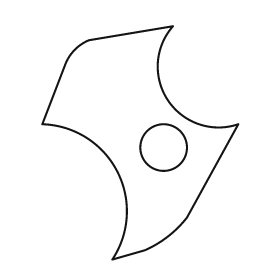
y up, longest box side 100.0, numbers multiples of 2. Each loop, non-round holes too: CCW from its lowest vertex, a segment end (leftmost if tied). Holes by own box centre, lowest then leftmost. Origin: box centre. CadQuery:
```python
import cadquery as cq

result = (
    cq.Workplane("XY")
    .moveTo(-12.0, -50.0)
    .lineTo(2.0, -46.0)
    .threePointArc((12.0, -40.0), (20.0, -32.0))
    .lineTo(42.0, 8.0)
    .threePointArc((12.0, 18.0), (14.0, 50.0))
    .lineTo(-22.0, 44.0)
    .threePointArc((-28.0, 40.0), (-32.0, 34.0))
    .lineTo(-42.0, 8.0)
    .threePointArc((-10.0, -12.0), (-12.0, -50.0))
    .close()
    .moveTo(10.0, -2.0)
    .circle(10.0)
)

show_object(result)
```